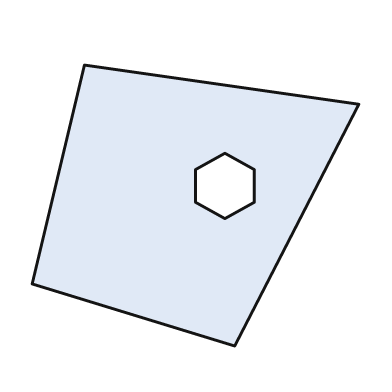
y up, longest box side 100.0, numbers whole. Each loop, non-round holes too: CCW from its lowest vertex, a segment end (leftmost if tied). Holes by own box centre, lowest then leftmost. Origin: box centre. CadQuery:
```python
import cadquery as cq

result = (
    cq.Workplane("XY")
    .moveTo(12.0, -43.0)
    .lineTo(50.0, 31.0)
    .lineTo(-34.0, 43.0)
    .lineTo(-50.0, -24.0)
    .close()
    .moveTo(9.0, -4.0)
    .lineTo(18.0, 1.0)
    .lineTo(18.0, 11.0)
    .lineTo(9.0, 16.0)
    .lineTo(0.0, 11.0)
    .lineTo(0.0, 1.0)
    .close()
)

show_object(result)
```